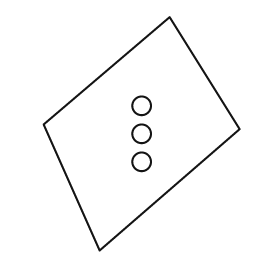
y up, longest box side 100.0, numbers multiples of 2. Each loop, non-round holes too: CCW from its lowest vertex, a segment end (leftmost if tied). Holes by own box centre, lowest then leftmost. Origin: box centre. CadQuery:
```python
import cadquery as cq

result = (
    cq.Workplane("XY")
    .moveTo(-18.0, -50.0)
    .lineTo(42.0, 2.0)
    .lineTo(12.0, 50.0)
    .lineTo(-42.0, 4.0)
    .close()
    .moveTo(0.0, -12.0)
    .circle(4.0)
    .moveTo(0.0, 0.0)
    .circle(4.0)
    .moveTo(0.0, 12.0)
    .circle(4.0)
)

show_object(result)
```